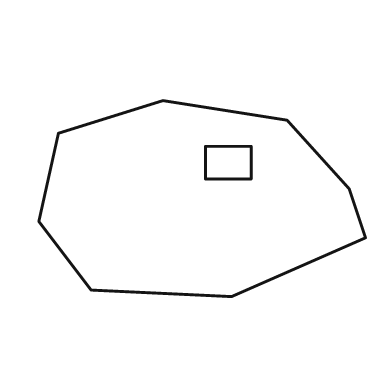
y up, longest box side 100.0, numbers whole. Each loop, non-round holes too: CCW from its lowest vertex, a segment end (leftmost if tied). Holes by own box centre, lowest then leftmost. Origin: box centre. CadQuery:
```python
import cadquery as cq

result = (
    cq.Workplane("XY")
    .moveTo(9.0, -30.0)
    .lineTo(50.0, -12.0)
    .lineTo(45.0, 3.0)
    .lineTo(26.0, 24.0)
    .lineTo(-12.0, 30.0)
    .lineTo(-44.0, 20.0)
    .lineTo(-50.0, -7.0)
    .lineTo(-34.0, -28.0)
    .close()
    .moveTo(1.0, 6.0)
    .lineTo(15.0, 6.0)
    .lineTo(15.0, 16.0)
    .lineTo(1.0, 16.0)
    .close()
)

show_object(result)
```